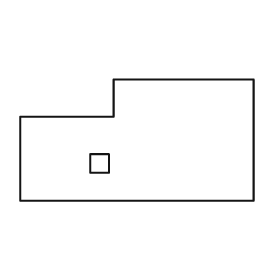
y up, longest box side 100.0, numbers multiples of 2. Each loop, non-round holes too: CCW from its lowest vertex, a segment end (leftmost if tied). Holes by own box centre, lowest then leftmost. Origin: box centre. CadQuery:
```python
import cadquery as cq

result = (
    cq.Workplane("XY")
    .moveTo(-50.0, -26.0)
    .lineTo(50.0, -26.0)
    .lineTo(50.0, 26.0)
    .lineTo(-10.0, 26.0)
    .lineTo(-10.0, 10.0)
    .lineTo(-50.0, 10.0)
    .close()
    .moveTo(-20.0, -14.0)
    .lineTo(-12.0, -14.0)
    .lineTo(-12.0, -6.0)
    .lineTo(-20.0, -6.0)
    .close()
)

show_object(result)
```